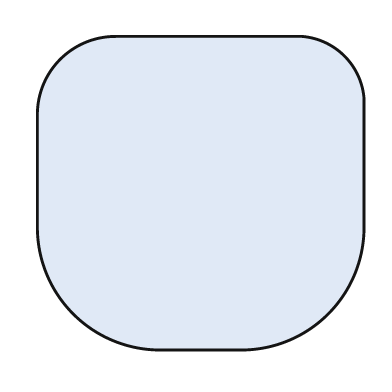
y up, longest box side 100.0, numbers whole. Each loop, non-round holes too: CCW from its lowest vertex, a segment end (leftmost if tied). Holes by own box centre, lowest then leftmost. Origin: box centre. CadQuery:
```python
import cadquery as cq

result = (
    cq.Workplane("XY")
    .moveTo(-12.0, -48.0)
    .lineTo(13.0, -48.0)
    .threePointArc((39.0, -37.0), (50.0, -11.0))
    .lineTo(50.0, 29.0)
    .threePointArc((44.0, 42.0), (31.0, 48.0))
    .lineTo(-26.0, 48.0)
    .threePointArc((-43.0, 41.0), (-50.0, 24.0))
    .lineTo(-50.0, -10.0)
    .threePointArc((-39.0, -37.0), (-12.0, -48.0))
    .close()
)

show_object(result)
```